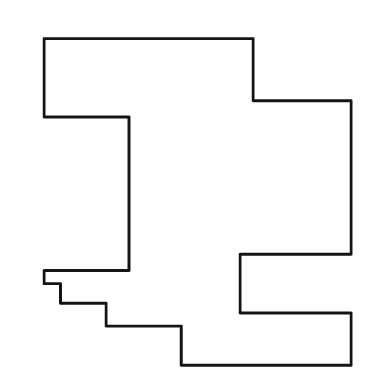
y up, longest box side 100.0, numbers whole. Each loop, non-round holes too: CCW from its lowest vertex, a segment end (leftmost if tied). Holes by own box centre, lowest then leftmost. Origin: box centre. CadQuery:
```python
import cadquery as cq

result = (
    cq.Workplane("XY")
    .moveTo(-5.0, -50.0)
    .lineTo(47.0, -50.0)
    .lineTo(47.0, -34.0)
    .lineTo(13.0, -34.0)
    .lineTo(13.0, -16.0)
    .lineTo(47.0, -16.0)
    .lineTo(47.0, 31.0)
    .lineTo(17.0, 31.0)
    .lineTo(17.0, 50.0)
    .lineTo(-47.0, 50.0)
    .lineTo(-47.0, 26.0)
    .lineTo(-21.0, 26.0)
    .lineTo(-21.0, -21.0)
    .lineTo(-47.0, -21.0)
    .lineTo(-47.0, -25.0)
    .lineTo(-42.0, -25.0)
    .lineTo(-42.0, -31.0)
    .lineTo(-28.0, -31.0)
    .lineTo(-28.0, -38.0)
    .lineTo(-5.0, -38.0)
    .close()
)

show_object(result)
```